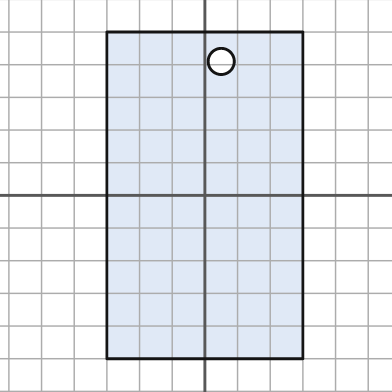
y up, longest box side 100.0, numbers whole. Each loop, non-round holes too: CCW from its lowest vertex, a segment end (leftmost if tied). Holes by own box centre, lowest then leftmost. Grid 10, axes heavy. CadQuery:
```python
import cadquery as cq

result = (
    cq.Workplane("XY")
    .moveTo(-30.0, -50.0)
    .lineTo(30.0, -50.0)
    .lineTo(30.0, 50.0)
    .lineTo(-30.0, 50.0)
    .close()
    .moveTo(5.0, 41.0)
    .circle(4.0)
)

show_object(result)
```